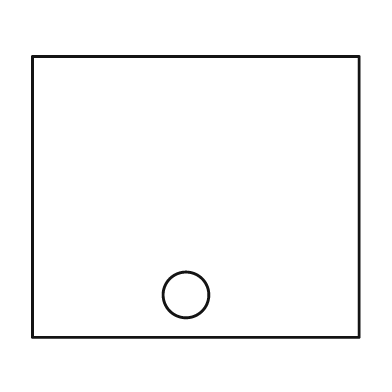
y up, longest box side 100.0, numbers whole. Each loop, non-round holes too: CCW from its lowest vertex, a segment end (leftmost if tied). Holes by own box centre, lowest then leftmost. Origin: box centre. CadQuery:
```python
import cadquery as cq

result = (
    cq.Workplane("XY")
    .moveTo(-50.0, -43.0)
    .lineTo(50.0, -43.0)
    .lineTo(50.0, 43.0)
    .lineTo(-50.0, 43.0)
    .close()
    .moveTo(-3.0, -30.0)
    .circle(7.0)
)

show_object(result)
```